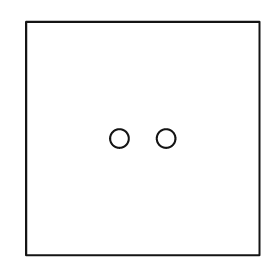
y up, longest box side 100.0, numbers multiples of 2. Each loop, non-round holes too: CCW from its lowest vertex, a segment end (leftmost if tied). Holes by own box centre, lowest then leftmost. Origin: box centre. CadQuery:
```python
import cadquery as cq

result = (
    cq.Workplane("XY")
    .moveTo(-50.0, -50.0)
    .lineTo(50.0, -50.0)
    .lineTo(50.0, 50.0)
    .lineTo(-50.0, 50.0)
    .close()
    .moveTo(-10.0, 0.0)
    .circle(4.0)
    .moveTo(10.0, 0.0)
    .circle(4.0)
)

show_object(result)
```